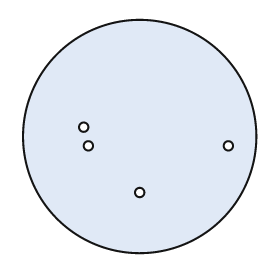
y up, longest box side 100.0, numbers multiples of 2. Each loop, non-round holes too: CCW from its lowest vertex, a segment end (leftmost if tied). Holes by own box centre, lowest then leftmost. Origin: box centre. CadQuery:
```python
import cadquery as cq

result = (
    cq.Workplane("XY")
    .moveTo(0.0, 0.0)
    .circle(50.0)
    .moveTo(0.0, -24.0)
    .circle(2.0)
    .moveTo(-22.0, -4.0)
    .circle(2.0)
    .moveTo(38.0, -4.0)
    .circle(2.0)
    .moveTo(-24.0, 4.0)
    .circle(2.0)
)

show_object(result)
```